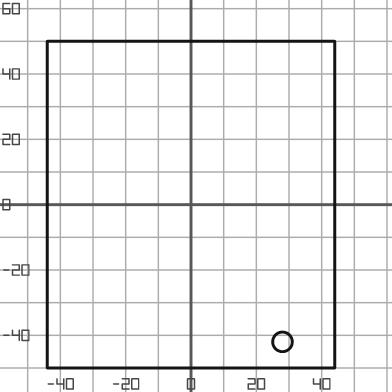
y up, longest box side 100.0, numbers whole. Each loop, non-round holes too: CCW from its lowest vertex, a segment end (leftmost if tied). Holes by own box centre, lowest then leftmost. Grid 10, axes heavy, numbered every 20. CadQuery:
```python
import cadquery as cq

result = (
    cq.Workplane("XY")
    .moveTo(-44.0, -50.0)
    .lineTo(44.0, -50.0)
    .lineTo(44.0, 50.0)
    .lineTo(-44.0, 50.0)
    .close()
    .moveTo(28.0, -42.0)
    .circle(3.0)
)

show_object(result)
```